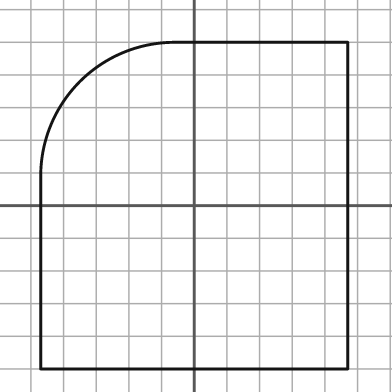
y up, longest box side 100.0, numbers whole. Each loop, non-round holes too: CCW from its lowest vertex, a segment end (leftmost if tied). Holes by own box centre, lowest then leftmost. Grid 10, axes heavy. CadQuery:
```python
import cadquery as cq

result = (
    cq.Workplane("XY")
    .moveTo(-47.0, -50.0)
    .lineTo(47.0, -50.0)
    .lineTo(47.0, 50.0)
    .lineTo(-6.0, 50.0)
    .threePointArc((-35.0, 38.0), (-47.0, 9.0))
    .close()
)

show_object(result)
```